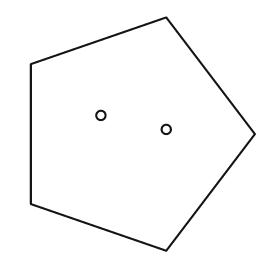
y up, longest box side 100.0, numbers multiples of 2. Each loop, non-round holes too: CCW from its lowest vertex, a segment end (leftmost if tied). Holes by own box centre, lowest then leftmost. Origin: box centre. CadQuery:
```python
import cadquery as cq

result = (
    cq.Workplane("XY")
    .moveTo(10.0, -50.0)
    .lineTo(48.0, 0.0)
    .lineTo(10.0, 50.0)
    .lineTo(-48.0, 30.0)
    .lineTo(-48.0, -30.0)
    .close()
    .moveTo(10.0, 2.0)
    .circle(2.0)
    .moveTo(-18.0, 8.0)
    .circle(2.0)
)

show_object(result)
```